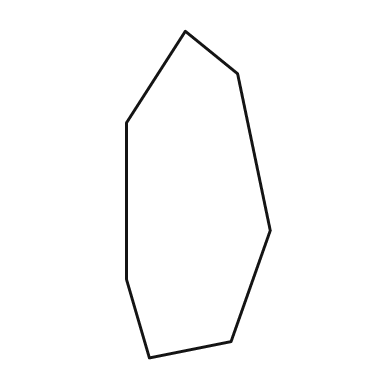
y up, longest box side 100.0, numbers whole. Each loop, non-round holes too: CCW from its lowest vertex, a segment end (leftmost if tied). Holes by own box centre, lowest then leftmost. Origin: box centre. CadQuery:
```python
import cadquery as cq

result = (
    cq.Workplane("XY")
    .moveTo(-15.0, -50.0)
    .lineTo(10.0, -45.0)
    .lineTo(22.0, -11.0)
    .lineTo(12.0, 37.0)
    .lineTo(-4.0, 50.0)
    .lineTo(-22.0, 22.0)
    .lineTo(-22.0, -26.0)
    .close()
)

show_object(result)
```